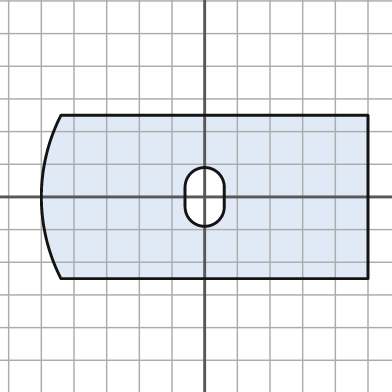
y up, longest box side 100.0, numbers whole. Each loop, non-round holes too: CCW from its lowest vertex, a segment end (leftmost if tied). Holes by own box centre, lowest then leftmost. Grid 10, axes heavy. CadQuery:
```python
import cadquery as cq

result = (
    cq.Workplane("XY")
    .moveTo(-44.0, -25.0)
    .lineTo(50.0, -25.0)
    .lineTo(50.0, 25.0)
    .lineTo(-44.0, 25.0)
    .threePointArc((-50.0, 0.0), (-44.0, -25.0))
    .close()
    .moveTo(-6.0, -3.0)
    .threePointArc((0.0, -9.0), (6.0, -3.0))
    .lineTo(6.0, 3.0)
    .threePointArc((0.0, 9.0), (-6.0, 3.0))
    .close()
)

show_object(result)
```